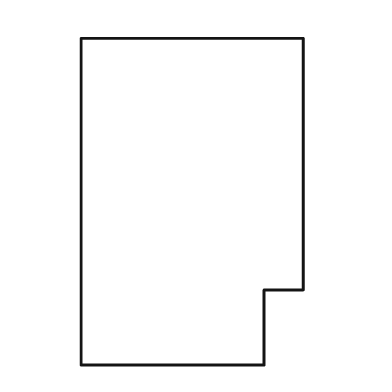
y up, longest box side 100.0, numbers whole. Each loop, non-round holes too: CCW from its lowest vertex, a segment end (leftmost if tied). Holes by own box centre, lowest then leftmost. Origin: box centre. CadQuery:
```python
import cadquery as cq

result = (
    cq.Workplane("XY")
    .moveTo(-34.0, -50.0)
    .lineTo(22.0, -50.0)
    .lineTo(22.0, -27.0)
    .lineTo(34.0, -27.0)
    .lineTo(34.0, 50.0)
    .lineTo(-34.0, 50.0)
    .close()
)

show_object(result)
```